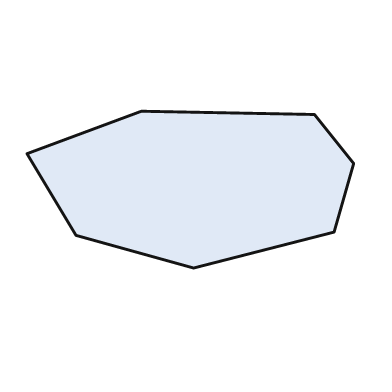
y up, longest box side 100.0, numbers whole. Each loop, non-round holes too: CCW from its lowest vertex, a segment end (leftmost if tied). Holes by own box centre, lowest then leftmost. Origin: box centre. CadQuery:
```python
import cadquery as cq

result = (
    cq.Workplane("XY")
    .moveTo(1.0, -24.0)
    .lineTo(44.0, -13.0)
    .lineTo(50.0, 8.0)
    .lineTo(38.0, 23.0)
    .lineTo(-15.0, 24.0)
    .lineTo(-50.0, 11.0)
    .lineTo(-35.0, -14.0)
    .close()
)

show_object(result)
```